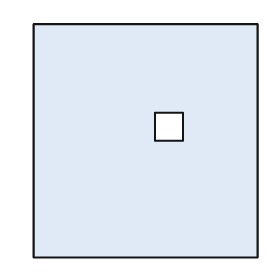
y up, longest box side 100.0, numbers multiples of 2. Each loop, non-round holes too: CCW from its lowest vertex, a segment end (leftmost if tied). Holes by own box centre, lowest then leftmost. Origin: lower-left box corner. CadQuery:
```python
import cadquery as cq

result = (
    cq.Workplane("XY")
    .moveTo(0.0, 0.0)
    .lineTo(96.0, 0.0)
    .lineTo(96.0, 100.0)
    .lineTo(0.0, 100.0)
    .close()
    .moveTo(52.0, 50.0)
    .lineTo(64.0, 50.0)
    .lineTo(64.0, 62.0)
    .lineTo(52.0, 62.0)
    .close()
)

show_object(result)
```